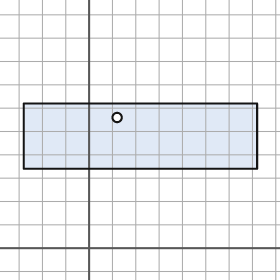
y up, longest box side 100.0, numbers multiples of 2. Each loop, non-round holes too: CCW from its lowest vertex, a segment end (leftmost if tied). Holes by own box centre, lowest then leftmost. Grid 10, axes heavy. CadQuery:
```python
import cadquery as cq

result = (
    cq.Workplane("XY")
    .moveTo(-28.0, 34.0)
    .lineTo(72.0, 34.0)
    .lineTo(72.0, 62.0)
    .lineTo(-28.0, 62.0)
    .close()
    .moveTo(12.0, 56.0)
    .circle(2.0)
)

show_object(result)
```